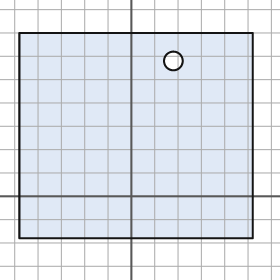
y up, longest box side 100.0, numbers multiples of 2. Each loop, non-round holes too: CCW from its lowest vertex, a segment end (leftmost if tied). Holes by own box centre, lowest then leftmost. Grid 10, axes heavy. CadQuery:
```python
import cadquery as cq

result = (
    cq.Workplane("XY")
    .moveTo(-48.0, -18.0)
    .lineTo(52.0, -18.0)
    .lineTo(52.0, 70.0)
    .lineTo(-48.0, 70.0)
    .close()
    .moveTo(18.0, 58.0)
    .circle(4.0)
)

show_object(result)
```